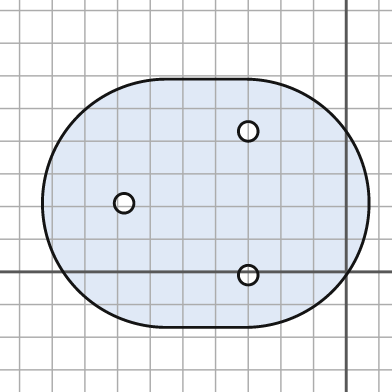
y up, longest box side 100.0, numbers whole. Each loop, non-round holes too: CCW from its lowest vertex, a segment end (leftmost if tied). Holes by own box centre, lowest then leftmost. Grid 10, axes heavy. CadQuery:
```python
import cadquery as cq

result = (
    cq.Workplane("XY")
    .moveTo(-55.0, -17.0)
    .lineTo(-31.0, -17.0)
    .threePointArc((7.0, 21.0), (-31.0, 59.0))
    .lineTo(-55.0, 59.0)
    .threePointArc((-93.0, 21.0), (-55.0, -17.0))
    .close()
    .moveTo(-30.0, -1.0)
    .circle(3.0)
    .moveTo(-68.0, 21.0)
    .circle(3.0)
    .moveTo(-30.0, 43.0)
    .circle(3.0)
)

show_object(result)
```